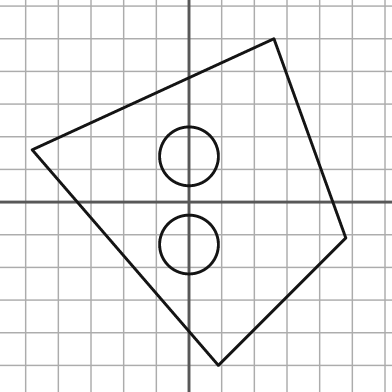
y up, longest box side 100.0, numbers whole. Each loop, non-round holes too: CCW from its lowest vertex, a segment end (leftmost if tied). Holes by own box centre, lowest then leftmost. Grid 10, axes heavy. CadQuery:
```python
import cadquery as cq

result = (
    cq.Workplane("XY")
    .moveTo(9.0, -50.0)
    .lineTo(48.0, -11.0)
    .lineTo(26.0, 50.0)
    .lineTo(-48.0, 16.0)
    .close()
    .moveTo(0.0, -13.0)
    .circle(9.0)
    .moveTo(0.0, 14.0)
    .circle(9.0)
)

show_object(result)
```